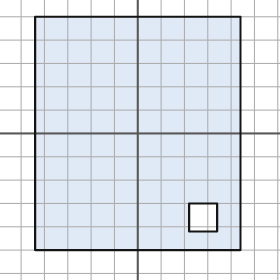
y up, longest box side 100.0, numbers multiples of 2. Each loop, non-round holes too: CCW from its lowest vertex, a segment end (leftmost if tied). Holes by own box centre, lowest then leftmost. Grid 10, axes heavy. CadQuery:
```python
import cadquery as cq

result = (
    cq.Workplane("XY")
    .moveTo(-44.0, -50.0)
    .lineTo(44.0, -50.0)
    .lineTo(44.0, 50.0)
    .lineTo(-44.0, 50.0)
    .close()
    .moveTo(22.0, -42.0)
    .lineTo(34.0, -42.0)
    .lineTo(34.0, -30.0)
    .lineTo(22.0, -30.0)
    .close()
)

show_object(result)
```